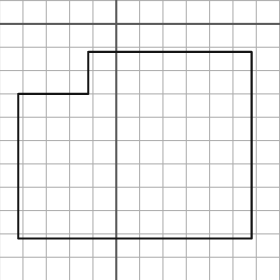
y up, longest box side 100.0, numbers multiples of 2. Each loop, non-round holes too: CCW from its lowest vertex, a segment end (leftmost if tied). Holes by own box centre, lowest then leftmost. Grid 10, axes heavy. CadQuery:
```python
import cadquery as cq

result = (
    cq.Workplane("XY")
    .moveTo(-42.0, -92.0)
    .lineTo(58.0, -92.0)
    .lineTo(58.0, -12.0)
    .lineTo(-12.0, -12.0)
    .lineTo(-12.0, -30.0)
    .lineTo(-42.0, -30.0)
    .close()
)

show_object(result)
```